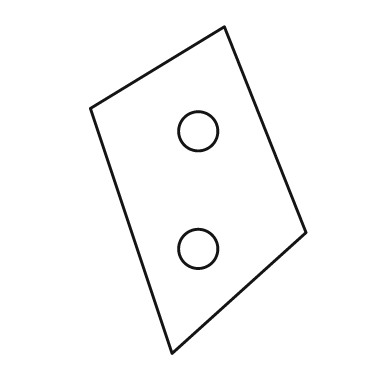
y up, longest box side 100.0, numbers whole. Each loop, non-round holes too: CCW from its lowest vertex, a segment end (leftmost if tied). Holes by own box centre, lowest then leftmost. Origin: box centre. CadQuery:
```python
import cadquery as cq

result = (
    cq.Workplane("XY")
    .moveTo(-8.0, -50.0)
    .lineTo(33.0, -13.0)
    .lineTo(8.0, 50.0)
    .lineTo(-33.0, 25.0)
    .close()
    .moveTo(0.0, -18.0)
    .circle(6.0)
    .moveTo(0.0, 18.0)
    .circle(6.0)
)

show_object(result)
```